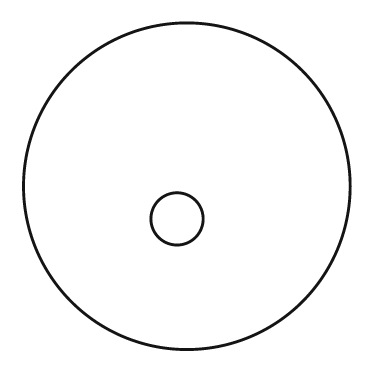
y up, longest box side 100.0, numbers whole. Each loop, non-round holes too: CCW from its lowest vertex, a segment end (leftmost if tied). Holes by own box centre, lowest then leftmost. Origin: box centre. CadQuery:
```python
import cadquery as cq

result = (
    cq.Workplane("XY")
    .moveTo(0.0, 0.0)
    .circle(50.0)
    .moveTo(-3.0, -10.0)
    .circle(8.0)
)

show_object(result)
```